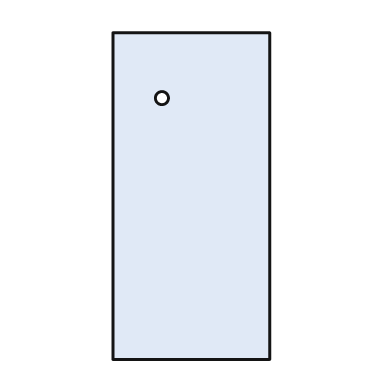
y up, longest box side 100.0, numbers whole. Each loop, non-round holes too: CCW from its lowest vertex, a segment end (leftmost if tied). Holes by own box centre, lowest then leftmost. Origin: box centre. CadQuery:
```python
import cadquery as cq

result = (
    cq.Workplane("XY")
    .moveTo(-24.0, -50.0)
    .lineTo(24.0, -50.0)
    .lineTo(24.0, 50.0)
    .lineTo(-24.0, 50.0)
    .close()
    .moveTo(-9.0, 30.0)
    .circle(2.0)
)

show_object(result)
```